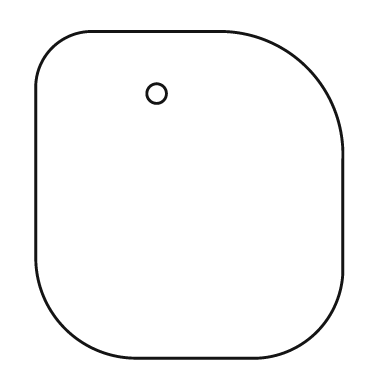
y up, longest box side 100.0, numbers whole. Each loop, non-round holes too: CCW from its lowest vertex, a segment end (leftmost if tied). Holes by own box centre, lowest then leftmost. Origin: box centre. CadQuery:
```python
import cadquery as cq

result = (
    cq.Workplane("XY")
    .moveTo(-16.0, -50.0)
    .lineTo(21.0, -50.0)
    .threePointArc((39.0, -42.0), (47.0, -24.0))
    .lineTo(47.0, 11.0)
    .threePointArc((36.0, 39.0), (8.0, 50.0))
    .lineTo(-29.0, 50.0)
    .threePointArc((-42.0, 45.0), (-47.0, 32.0))
    .lineTo(-47.0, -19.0)
    .threePointArc((-38.0, -41.0), (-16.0, -50.0))
    .close()
    .moveTo(-10.0, 31.0)
    .circle(3.0)
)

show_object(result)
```